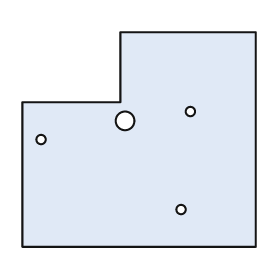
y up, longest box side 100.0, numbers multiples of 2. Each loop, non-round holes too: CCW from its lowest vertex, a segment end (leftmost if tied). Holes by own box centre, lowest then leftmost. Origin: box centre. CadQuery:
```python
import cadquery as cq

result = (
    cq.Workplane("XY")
    .moveTo(-50.0, -46.0)
    .lineTo(50.0, -46.0)
    .lineTo(50.0, 46.0)
    .lineTo(-8.0, 46.0)
    .lineTo(-8.0, 16.0)
    .lineTo(-50.0, 16.0)
    .close()
    .moveTo(18.0, -30.0)
    .circle(2.0)
    .moveTo(-42.0, 0.0)
    .circle(2.0)
    .moveTo(-6.0, 8.0)
    .circle(4.0)
    .moveTo(22.0, 12.0)
    .circle(2.0)
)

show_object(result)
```